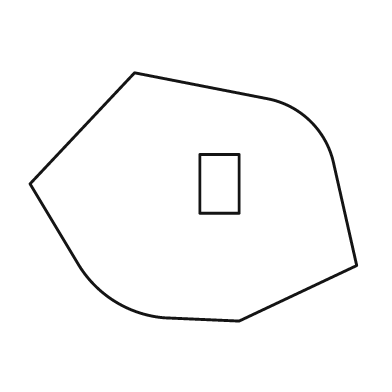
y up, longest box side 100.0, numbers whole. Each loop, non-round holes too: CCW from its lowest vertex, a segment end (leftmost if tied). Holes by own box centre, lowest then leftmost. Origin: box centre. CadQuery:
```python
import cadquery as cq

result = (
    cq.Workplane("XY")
    .moveTo(14.0, -38.0)
    .lineTo(50.0, -21.0)
    .lineTo(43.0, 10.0)
    .threePointArc((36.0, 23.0), (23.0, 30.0))
    .lineTo(-18.0, 38.0)
    .lineTo(-50.0, 4.0)
    .lineTo(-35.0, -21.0)
    .threePointArc((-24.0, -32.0), (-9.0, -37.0))
    .close()
    .moveTo(2.0, -5.0)
    .lineTo(14.0, -5.0)
    .lineTo(14.0, 13.0)
    .lineTo(2.0, 13.0)
    .close()
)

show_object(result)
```